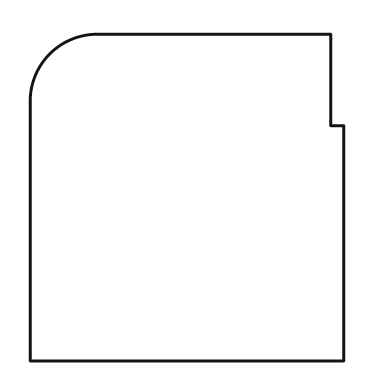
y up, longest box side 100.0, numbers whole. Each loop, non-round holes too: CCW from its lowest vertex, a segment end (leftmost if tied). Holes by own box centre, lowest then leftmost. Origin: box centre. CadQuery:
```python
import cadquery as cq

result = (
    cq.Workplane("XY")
    .moveTo(-48.0, -50.0)
    .lineTo(48.0, -50.0)
    .lineTo(48.0, 22.0)
    .lineTo(44.0, 22.0)
    .lineTo(44.0, 50.0)
    .lineTo(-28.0, 50.0)
    .threePointArc((-42.0, 44.0), (-48.0, 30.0))
    .close()
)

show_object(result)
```